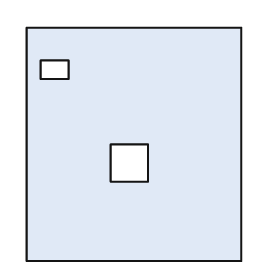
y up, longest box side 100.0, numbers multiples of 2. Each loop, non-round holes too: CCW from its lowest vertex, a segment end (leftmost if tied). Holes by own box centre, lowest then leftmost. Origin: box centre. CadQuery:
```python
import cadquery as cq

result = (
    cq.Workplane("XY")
    .moveTo(-46.0, -50.0)
    .lineTo(46.0, -50.0)
    .lineTo(46.0, 50.0)
    .lineTo(-46.0, 50.0)
    .close()
    .moveTo(-10.0, -16.0)
    .lineTo(6.0, -16.0)
    .lineTo(6.0, 0.0)
    .lineTo(-10.0, 0.0)
    .close()
    .moveTo(-40.0, 28.0)
    .lineTo(-28.0, 28.0)
    .lineTo(-28.0, 36.0)
    .lineTo(-40.0, 36.0)
    .close()
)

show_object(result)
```